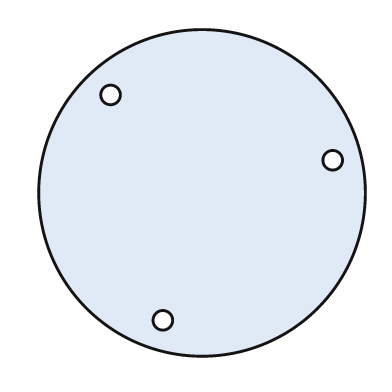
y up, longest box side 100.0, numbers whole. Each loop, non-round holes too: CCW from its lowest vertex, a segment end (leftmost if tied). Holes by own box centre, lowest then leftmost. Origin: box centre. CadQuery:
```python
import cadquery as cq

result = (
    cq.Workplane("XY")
    .moveTo(0.0, 0.0)
    .circle(50.0)
    .moveTo(-12.0, -39.0)
    .circle(3.0)
    .moveTo(40.0, 10.0)
    .circle(3.0)
    .moveTo(-28.0, 30.0)
    .circle(3.0)
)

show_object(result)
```